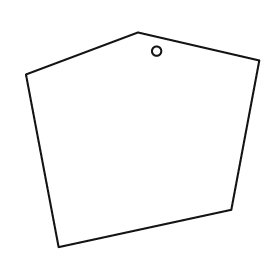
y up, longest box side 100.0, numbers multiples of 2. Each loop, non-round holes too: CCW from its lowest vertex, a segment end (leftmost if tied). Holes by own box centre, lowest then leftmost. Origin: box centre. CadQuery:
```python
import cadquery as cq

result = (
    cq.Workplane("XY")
    .moveTo(-36.0, -46.0)
    .lineTo(38.0, -30.0)
    .lineTo(50.0, 34.0)
    .lineTo(-2.0, 46.0)
    .lineTo(-50.0, 28.0)
    .close()
    .moveTo(6.0, 38.0)
    .circle(2.0)
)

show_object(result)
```